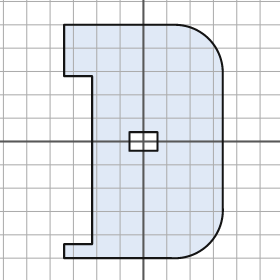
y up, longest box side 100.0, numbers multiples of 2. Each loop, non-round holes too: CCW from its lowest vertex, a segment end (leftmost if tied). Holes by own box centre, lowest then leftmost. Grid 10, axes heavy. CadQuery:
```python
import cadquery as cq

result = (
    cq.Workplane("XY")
    .moveTo(-34.0, -50.0)
    .lineTo(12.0, -50.0)
    .threePointArc((28.0, -44.0), (34.0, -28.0))
    .lineTo(34.0, 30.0)
    .threePointArc((28.0, 44.0), (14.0, 50.0))
    .lineTo(-34.0, 50.0)
    .lineTo(-34.0, 28.0)
    .lineTo(-22.0, 28.0)
    .lineTo(-22.0, -44.0)
    .lineTo(-34.0, -44.0)
    .close()
    .moveTo(-6.0, -4.0)
    .lineTo(6.0, -4.0)
    .lineTo(6.0, 4.0)
    .lineTo(-6.0, 4.0)
    .close()
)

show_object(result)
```